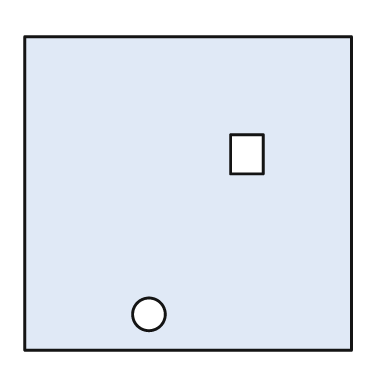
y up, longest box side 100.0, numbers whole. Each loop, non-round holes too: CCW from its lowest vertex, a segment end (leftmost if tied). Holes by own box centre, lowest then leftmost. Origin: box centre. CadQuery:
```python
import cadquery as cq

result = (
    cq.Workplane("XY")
    .moveTo(-50.0, -48.0)
    .lineTo(50.0, -48.0)
    .lineTo(50.0, 48.0)
    .lineTo(-50.0, 48.0)
    .close()
    .moveTo(-12.0, -37.0)
    .circle(5.0)
    .moveTo(13.0, 6.0)
    .lineTo(23.0, 6.0)
    .lineTo(23.0, 18.0)
    .lineTo(13.0, 18.0)
    .close()
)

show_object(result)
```